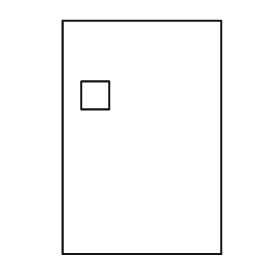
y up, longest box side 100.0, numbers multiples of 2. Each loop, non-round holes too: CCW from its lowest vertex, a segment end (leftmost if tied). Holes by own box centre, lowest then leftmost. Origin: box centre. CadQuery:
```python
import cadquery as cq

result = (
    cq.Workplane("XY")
    .moveTo(-34.0, -50.0)
    .lineTo(34.0, -50.0)
    .lineTo(34.0, 50.0)
    .lineTo(-34.0, 50.0)
    .close()
    .moveTo(-26.0, 12.0)
    .lineTo(-14.0, 12.0)
    .lineTo(-14.0, 24.0)
    .lineTo(-26.0, 24.0)
    .close()
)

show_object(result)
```